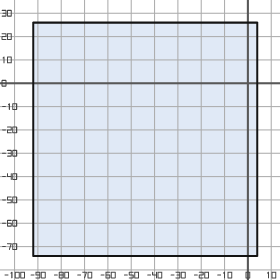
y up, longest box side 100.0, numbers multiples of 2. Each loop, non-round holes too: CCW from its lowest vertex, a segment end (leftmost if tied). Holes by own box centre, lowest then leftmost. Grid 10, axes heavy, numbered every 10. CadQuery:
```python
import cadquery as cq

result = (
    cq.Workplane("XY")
    .moveTo(-92.0, -74.0)
    .lineTo(4.0, -74.0)
    .lineTo(4.0, 26.0)
    .lineTo(-92.0, 26.0)
    .close()
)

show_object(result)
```